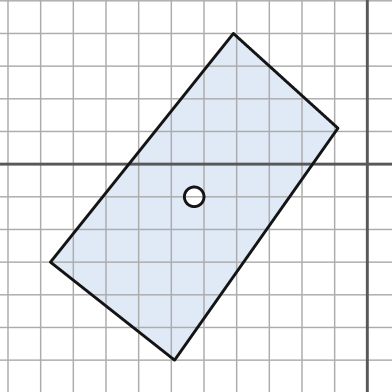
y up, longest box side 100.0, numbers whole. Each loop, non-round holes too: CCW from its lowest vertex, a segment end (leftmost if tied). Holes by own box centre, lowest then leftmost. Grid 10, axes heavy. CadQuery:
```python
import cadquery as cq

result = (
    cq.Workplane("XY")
    .moveTo(-59.0, -60.0)
    .lineTo(-9.0, 11.0)
    .lineTo(-41.0, 40.0)
    .lineTo(-97.0, -30.0)
    .close()
    .moveTo(-53.0, -10.0)
    .circle(3.0)
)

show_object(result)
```